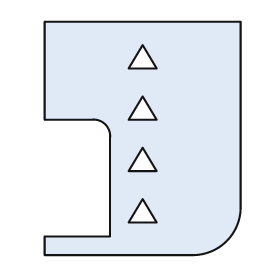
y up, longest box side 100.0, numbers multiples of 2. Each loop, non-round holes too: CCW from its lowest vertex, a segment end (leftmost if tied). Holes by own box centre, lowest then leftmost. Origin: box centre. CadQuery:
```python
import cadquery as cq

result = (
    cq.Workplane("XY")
    .moveTo(-42.0, -50.0)
    .lineTo(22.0, -50.0)
    .threePointArc((36.0, -44.0), (42.0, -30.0))
    .lineTo(42.0, 50.0)
    .lineTo(-42.0, 50.0)
    .lineTo(-42.0, 8.0)
    .lineTo(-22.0, 8.0)
    .threePointArc((-16.0, 6.0), (-14.0, 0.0))
    .lineTo(-14.0, -42.0)
    .lineTo(-42.0, -42.0)
    .close()
    .moveTo(-6.0, -36.0)
    .lineTo(6.0, -36.0)
    .lineTo(0.0, -26.0)
    .close()
    .moveTo(-6.0, -14.0)
    .lineTo(6.0, -14.0)
    .lineTo(0.0, -4.0)
    .close()
    .moveTo(-6.0, 8.0)
    .lineTo(6.0, 8.0)
    .lineTo(0.0, 18.0)
    .close()
    .moveTo(-6.0, 30.0)
    .lineTo(6.0, 30.0)
    .lineTo(0.0, 40.0)
    .close()
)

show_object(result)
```